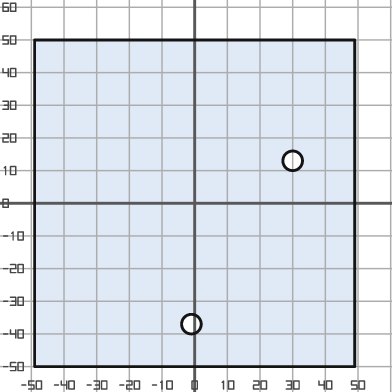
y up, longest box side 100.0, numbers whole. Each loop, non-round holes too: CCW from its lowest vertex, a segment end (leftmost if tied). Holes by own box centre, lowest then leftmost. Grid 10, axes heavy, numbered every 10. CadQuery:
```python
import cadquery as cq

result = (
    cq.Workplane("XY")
    .moveTo(-49.0, -50.0)
    .lineTo(49.0, -50.0)
    .lineTo(49.0, 50.0)
    .lineTo(-49.0, 50.0)
    .close()
    .moveTo(-1.0, -37.0)
    .circle(3.0)
    .moveTo(30.0, 13.0)
    .circle(3.0)
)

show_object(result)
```